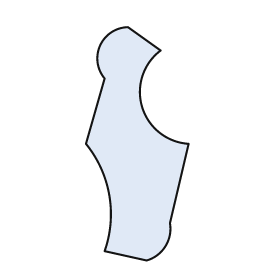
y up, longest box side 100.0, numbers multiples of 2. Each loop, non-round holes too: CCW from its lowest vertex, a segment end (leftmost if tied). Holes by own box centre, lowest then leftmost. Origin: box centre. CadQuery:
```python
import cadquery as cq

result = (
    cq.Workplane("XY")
    .moveTo(4.0, -50.0)
    .threePointArc((12.0, -44.0), (14.0, -34.0))
    .lineTo(22.0, 0.0)
    .threePointArc((2.0, 16.0), (10.0, 40.0))
    .lineTo(-4.0, 50.0)
    .threePointArc((-16.0, 42.0), (-14.0, 28.0))
    .lineTo(-22.0, 0.0)
    .threePointArc((-12.0, -22.0), (-14.0, -46.0))
    .close()
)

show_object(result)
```